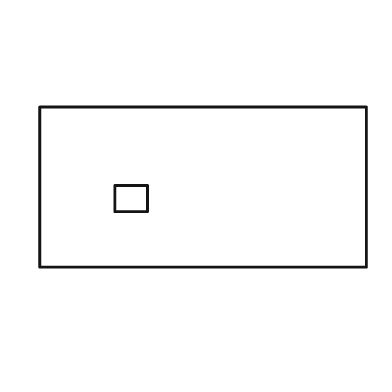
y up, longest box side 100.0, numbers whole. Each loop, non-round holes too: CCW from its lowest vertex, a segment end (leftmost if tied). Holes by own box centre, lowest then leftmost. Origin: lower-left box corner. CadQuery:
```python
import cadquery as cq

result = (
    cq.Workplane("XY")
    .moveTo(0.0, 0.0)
    .lineTo(100.0, 0.0)
    .lineTo(100.0, 49.0)
    .lineTo(0.0, 49.0)
    .close()
    .moveTo(23.0, 17.0)
    .lineTo(33.0, 17.0)
    .lineTo(33.0, 25.0)
    .lineTo(23.0, 25.0)
    .close()
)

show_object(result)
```